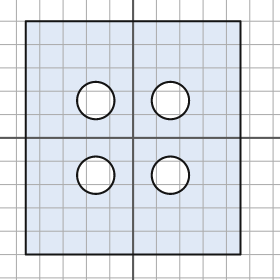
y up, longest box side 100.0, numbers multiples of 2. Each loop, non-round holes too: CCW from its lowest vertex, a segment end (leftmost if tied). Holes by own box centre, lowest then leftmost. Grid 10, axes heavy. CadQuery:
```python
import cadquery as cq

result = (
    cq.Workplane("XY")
    .moveTo(-46.0, -50.0)
    .lineTo(46.0, -50.0)
    .lineTo(46.0, 50.0)
    .lineTo(-46.0, 50.0)
    .close()
    .moveTo(-16.0, -16.0)
    .circle(8.0)
    .moveTo(16.0, -16.0)
    .circle(8.0)
    .moveTo(-16.0, 16.0)
    .circle(8.0)
    .moveTo(16.0, 16.0)
    .circle(8.0)
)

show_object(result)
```